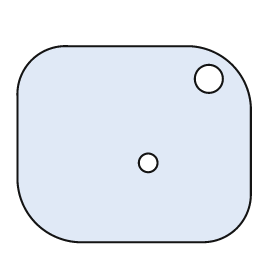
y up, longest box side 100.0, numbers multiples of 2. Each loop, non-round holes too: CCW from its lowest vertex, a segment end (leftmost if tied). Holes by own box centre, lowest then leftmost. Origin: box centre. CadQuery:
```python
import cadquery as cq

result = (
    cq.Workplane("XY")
    .moveTo(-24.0, -42.0)
    .lineTo(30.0, -42.0)
    .threePointArc((44.0, -36.0), (50.0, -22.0))
    .lineTo(50.0, 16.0)
    .threePointArc((42.0, 34.0), (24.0, 42.0))
    .lineTo(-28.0, 42.0)
    .threePointArc((-44.0, 36.0), (-50.0, 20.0))
    .lineTo(-50.0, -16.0)
    .threePointArc((-42.0, -34.0), (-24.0, -42.0))
    .close()
    .moveTo(6.0, -8.0)
    .circle(4.0)
    .moveTo(32.0, 28.0)
    .circle(6.0)
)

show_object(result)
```